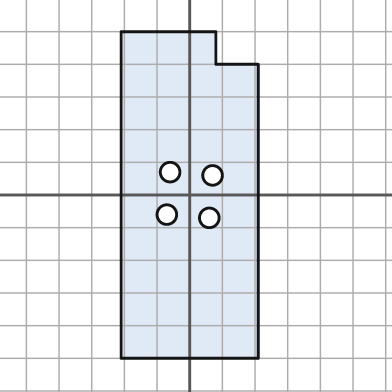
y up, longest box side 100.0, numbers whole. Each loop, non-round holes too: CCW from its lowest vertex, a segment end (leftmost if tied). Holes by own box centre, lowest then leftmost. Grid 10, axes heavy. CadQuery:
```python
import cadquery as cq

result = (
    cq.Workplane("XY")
    .moveTo(-21.0, -50.0)
    .lineTo(21.0, -50.0)
    .lineTo(21.0, 40.0)
    .lineTo(8.0, 40.0)
    .lineTo(8.0, 50.0)
    .lineTo(-21.0, 50.0)
    .close()
    .moveTo(6.0, -7.0)
    .circle(3.0)
    .moveTo(-7.0, -6.0)
    .circle(3.0)
    .moveTo(7.0, 6.0)
    .circle(3.0)
    .moveTo(-6.0, 7.0)
    .circle(3.0)
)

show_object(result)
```